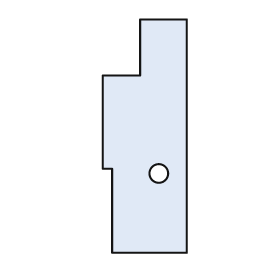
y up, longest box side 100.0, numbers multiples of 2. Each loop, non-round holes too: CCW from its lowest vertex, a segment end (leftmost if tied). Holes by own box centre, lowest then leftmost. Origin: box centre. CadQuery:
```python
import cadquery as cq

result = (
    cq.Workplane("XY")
    .moveTo(-14.0, -50.0)
    .lineTo(18.0, -50.0)
    .lineTo(18.0, 50.0)
    .lineTo(-2.0, 50.0)
    .lineTo(-2.0, 26.0)
    .lineTo(-18.0, 26.0)
    .lineTo(-18.0, -14.0)
    .lineTo(-14.0, -14.0)
    .close()
    .moveTo(6.0, -16.0)
    .circle(4.0)
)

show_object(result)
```